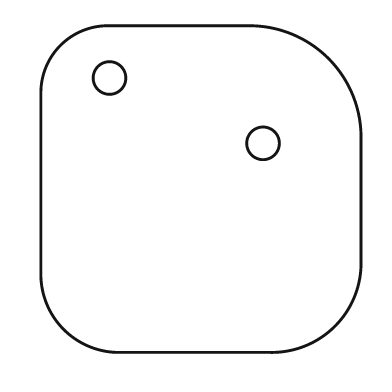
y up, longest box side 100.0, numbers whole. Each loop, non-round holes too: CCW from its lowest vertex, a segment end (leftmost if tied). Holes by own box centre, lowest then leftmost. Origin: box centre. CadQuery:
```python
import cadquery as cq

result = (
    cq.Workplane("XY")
    .moveTo(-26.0, -50.0)
    .lineTo(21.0, -50.0)
    .threePointArc((41.0, -42.0), (49.0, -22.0))
    .lineTo(49.0, 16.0)
    .threePointArc((39.0, 40.0), (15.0, 50.0))
    .lineTo(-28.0, 50.0)
    .threePointArc((-43.0, 44.0), (-49.0, 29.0))
    .lineTo(-49.0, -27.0)
    .threePointArc((-42.0, -43.0), (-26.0, -50.0))
    .close()
    .moveTo(19.0, 14.0)
    .circle(5.0)
    .moveTo(-28.0, 34.0)
    .circle(5.0)
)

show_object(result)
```